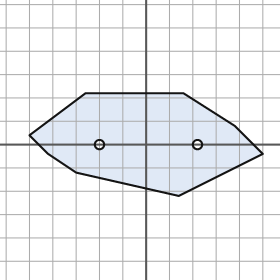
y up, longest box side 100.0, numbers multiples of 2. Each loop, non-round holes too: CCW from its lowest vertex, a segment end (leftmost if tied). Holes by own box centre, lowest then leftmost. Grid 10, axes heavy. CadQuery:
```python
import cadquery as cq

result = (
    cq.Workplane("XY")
    .moveTo(14.0, -22.0)
    .lineTo(50.0, -4.0)
    .lineTo(38.0, 8.0)
    .lineTo(16.0, 22.0)
    .lineTo(-26.0, 22.0)
    .lineTo(-50.0, 4.0)
    .lineTo(-42.0, -4.0)
    .lineTo(-30.0, -12.0)
    .close()
    .moveTo(-20.0, 0.0)
    .circle(2.0)
    .moveTo(22.0, 0.0)
    .circle(2.0)
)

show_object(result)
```